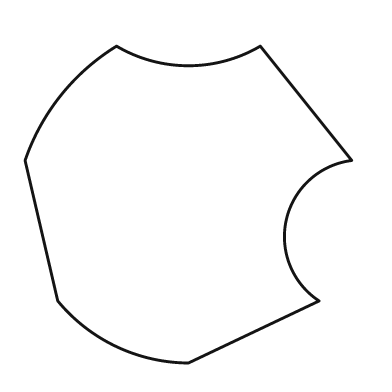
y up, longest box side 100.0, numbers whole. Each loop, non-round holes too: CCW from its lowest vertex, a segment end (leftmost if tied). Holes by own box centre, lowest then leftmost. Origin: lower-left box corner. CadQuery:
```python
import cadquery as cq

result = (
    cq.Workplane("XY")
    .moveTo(50.0, 0.0)
    .lineTo(90.0, 19.0)
    .threePointArc((80.0, 44.0), (100.0, 62.0))
    .lineTo(72.0, 97.0)
    .threePointArc((50.0, 91.0), (28.0, 97.0))
    .threePointArc((11.0, 82.0), (0.0, 62.0))
    .lineTo(10.0, 19.0)
    .threePointArc((28.0, 5.0), (50.0, 0.0))
    .close()
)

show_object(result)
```